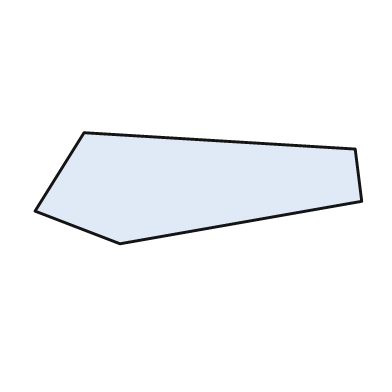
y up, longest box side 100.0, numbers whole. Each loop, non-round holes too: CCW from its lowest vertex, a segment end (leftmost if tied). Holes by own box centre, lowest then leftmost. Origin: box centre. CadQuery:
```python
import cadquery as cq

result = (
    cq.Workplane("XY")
    .moveTo(-24.0, -17.0)
    .lineTo(50.0, -4.0)
    .lineTo(48.0, 12.0)
    .lineTo(-35.0, 17.0)
    .lineTo(-50.0, -7.0)
    .close()
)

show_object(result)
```